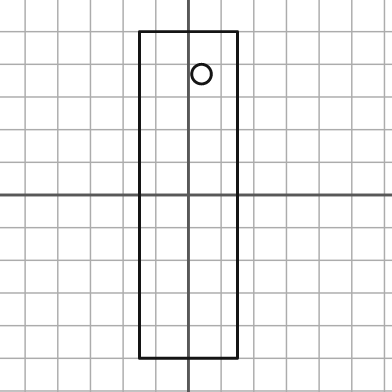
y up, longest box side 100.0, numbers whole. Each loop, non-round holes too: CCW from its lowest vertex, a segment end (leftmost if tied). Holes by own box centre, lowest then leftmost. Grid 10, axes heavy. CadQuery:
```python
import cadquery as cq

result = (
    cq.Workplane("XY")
    .moveTo(-15.0, -50.0)
    .lineTo(15.0, -50.0)
    .lineTo(15.0, 50.0)
    .lineTo(-15.0, 50.0)
    .close()
    .moveTo(4.0, 37.0)
    .circle(3.0)
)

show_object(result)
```